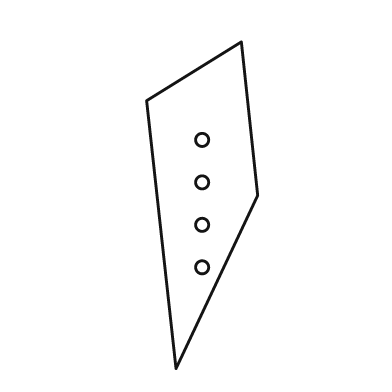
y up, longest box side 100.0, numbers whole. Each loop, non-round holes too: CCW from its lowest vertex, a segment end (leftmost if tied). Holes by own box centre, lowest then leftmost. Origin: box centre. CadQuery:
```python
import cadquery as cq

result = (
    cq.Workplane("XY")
    .moveTo(-8.0, -50.0)
    .lineTo(17.0, 3.0)
    .lineTo(12.0, 50.0)
    .lineTo(-17.0, 32.0)
    .close()
    .moveTo(0.0, -19.0)
    .circle(2.0)
    .moveTo(0.0, -6.0)
    .circle(2.0)
    .moveTo(0.0, 7.0)
    .circle(2.0)
    .moveTo(0.0, 20.0)
    .circle(2.0)
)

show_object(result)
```